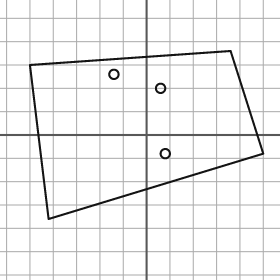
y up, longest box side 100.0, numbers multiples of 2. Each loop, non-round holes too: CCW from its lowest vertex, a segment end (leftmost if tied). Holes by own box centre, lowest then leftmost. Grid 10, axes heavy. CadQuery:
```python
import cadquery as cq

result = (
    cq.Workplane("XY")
    .moveTo(-42.0, -36.0)
    .lineTo(50.0, -8.0)
    .lineTo(36.0, 36.0)
    .lineTo(-50.0, 30.0)
    .close()
    .moveTo(8.0, -8.0)
    .circle(2.0)
    .moveTo(6.0, 20.0)
    .circle(2.0)
    .moveTo(-14.0, 26.0)
    .circle(2.0)
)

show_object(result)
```